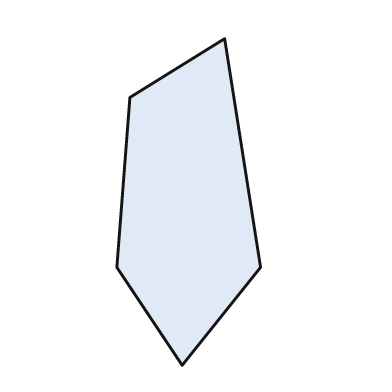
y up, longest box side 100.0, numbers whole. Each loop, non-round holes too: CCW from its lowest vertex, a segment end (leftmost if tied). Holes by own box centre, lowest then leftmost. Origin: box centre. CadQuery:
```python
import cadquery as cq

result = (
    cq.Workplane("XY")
    .moveTo(-2.0, -50.0)
    .lineTo(22.0, -20.0)
    .lineTo(11.0, 50.0)
    .lineTo(-18.0, 32.0)
    .lineTo(-22.0, -20.0)
    .close()
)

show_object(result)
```